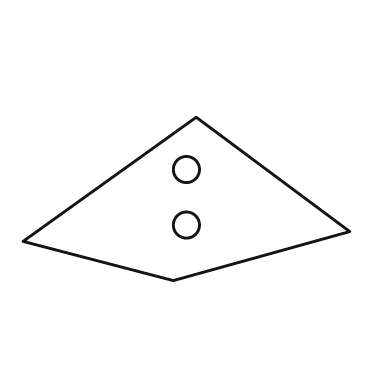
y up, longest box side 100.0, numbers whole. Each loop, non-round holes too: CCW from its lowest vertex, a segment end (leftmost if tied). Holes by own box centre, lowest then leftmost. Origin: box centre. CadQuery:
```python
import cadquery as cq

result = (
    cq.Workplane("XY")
    .moveTo(-4.0, -25.0)
    .lineTo(50.0, -10.0)
    .lineTo(3.0, 25.0)
    .lineTo(-50.0, -13.0)
    .close()
    .moveTo(0.0, -8.0)
    .circle(4.0)
    .moveTo(0.0, 9.0)
    .circle(4.0)
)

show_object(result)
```